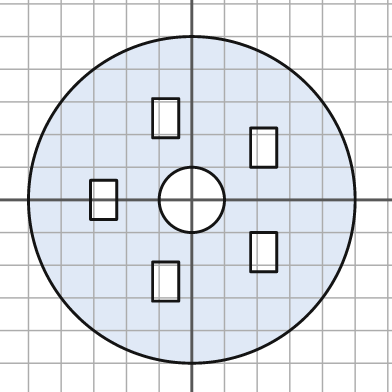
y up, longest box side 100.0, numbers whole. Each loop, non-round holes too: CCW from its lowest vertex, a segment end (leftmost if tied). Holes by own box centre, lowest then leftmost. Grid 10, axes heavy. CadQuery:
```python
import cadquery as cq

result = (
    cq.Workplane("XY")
    .moveTo(0.0, 0.0)
    .circle(50.0)
    .moveTo(-12.0, -31.0)
    .lineTo(-4.0, -31.0)
    .lineTo(-4.0, -19.0)
    .lineTo(-12.0, -19.0)
    .close()
    .moveTo(18.0, -22.0)
    .lineTo(26.0, -22.0)
    .lineTo(26.0, -10.0)
    .lineTo(18.0, -10.0)
    .close()
    .moveTo(-31.0, -6.0)
    .lineTo(-23.0, -6.0)
    .lineTo(-23.0, 6.0)
    .lineTo(-31.0, 6.0)
    .close()
    .moveTo(0.0, 0.0)
    .circle(10.0)
    .moveTo(18.0, 10.0)
    .lineTo(26.0, 10.0)
    .lineTo(26.0, 22.0)
    .lineTo(18.0, 22.0)
    .close()
    .moveTo(-12.0, 19.0)
    .lineTo(-4.0, 19.0)
    .lineTo(-4.0, 31.0)
    .lineTo(-12.0, 31.0)
    .close()
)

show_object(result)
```